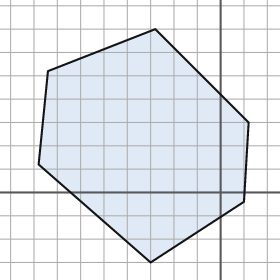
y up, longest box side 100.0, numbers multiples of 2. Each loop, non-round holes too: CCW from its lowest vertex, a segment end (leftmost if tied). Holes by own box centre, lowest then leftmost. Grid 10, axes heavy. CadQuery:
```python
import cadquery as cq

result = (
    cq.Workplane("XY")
    .moveTo(-30.0, -30.0)
    .lineTo(10.0, -4.0)
    .lineTo(12.0, 30.0)
    .lineTo(-28.0, 70.0)
    .lineTo(-74.0, 52.0)
    .lineTo(-78.0, 12.0)
    .close()
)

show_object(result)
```